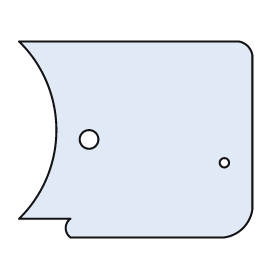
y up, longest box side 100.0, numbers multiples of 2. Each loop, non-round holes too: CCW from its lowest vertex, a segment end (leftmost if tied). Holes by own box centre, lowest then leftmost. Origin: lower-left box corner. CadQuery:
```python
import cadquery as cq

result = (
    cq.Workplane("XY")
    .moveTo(22.0, 0.0)
    .lineTo(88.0, 0.0)
    .threePointArc((96.0, 4.0), (100.0, 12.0))
    .lineTo(100.0, 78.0)
    .threePointArc((98.0, 82.0), (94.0, 84.0))
    .lineTo(0.0, 84.0)
    .threePointArc((16.0, 46.0), (0.0, 8.0))
    .lineTo(22.0, 8.0)
    .threePointArc((20.0, 4.0), (22.0, 0.0))
    .close()
    .moveTo(88.0, 32.0)
    .circle(2.0)
    .moveTo(30.0, 42.0)
    .circle(4.0)
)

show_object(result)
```